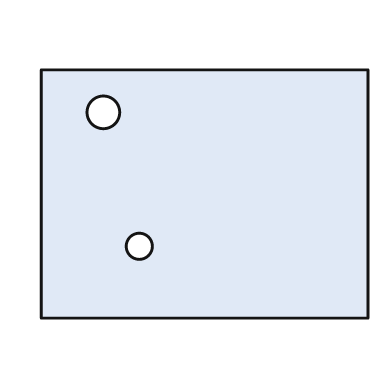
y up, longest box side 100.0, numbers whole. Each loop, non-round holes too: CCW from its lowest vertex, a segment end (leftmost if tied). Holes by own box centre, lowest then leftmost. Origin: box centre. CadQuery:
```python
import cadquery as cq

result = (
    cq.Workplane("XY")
    .moveTo(-50.0, -38.0)
    .lineTo(50.0, -38.0)
    .lineTo(50.0, 38.0)
    .lineTo(-50.0, 38.0)
    .close()
    .moveTo(-20.0, -16.0)
    .circle(4.0)
    .moveTo(-31.0, 25.0)
    .circle(5.0)
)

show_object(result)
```